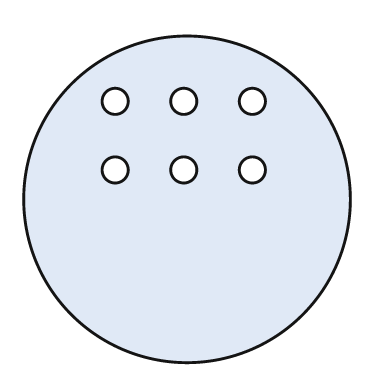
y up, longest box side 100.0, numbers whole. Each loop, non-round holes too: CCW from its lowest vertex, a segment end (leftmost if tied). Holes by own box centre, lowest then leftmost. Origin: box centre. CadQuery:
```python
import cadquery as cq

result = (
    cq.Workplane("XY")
    .moveTo(0.0, 0.0)
    .circle(50.0)
    .moveTo(-22.0, 9.0)
    .circle(4.0)
    .moveTo(-1.0, 9.0)
    .circle(4.0)
    .moveTo(20.0, 9.0)
    .circle(4.0)
    .moveTo(-22.0, 30.0)
    .circle(4.0)
    .moveTo(-1.0, 30.0)
    .circle(4.0)
    .moveTo(20.0, 30.0)
    .circle(4.0)
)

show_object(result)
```